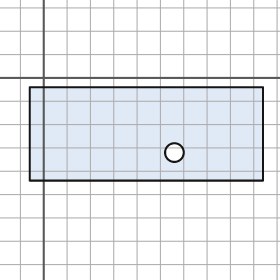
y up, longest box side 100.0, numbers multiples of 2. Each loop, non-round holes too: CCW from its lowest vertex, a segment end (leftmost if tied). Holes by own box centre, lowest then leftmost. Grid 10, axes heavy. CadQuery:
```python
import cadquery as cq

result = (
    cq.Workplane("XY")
    .moveTo(-6.0, -44.0)
    .lineTo(94.0, -44.0)
    .lineTo(94.0, -4.0)
    .lineTo(-6.0, -4.0)
    .close()
    .moveTo(56.0, -32.0)
    .circle(4.0)
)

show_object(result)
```